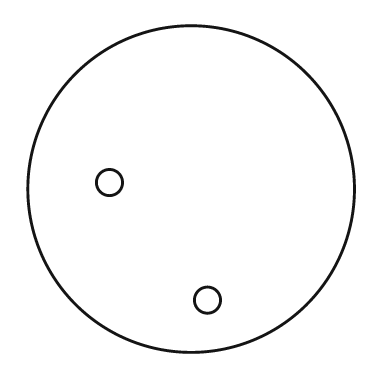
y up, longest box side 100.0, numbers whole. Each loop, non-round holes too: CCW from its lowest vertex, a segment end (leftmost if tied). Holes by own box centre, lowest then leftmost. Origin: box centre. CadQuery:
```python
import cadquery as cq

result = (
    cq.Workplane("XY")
    .moveTo(0.0, 0.0)
    .circle(50.0)
    .moveTo(5.0, -34.0)
    .circle(4.0)
    .moveTo(-25.0, 2.0)
    .circle(4.0)
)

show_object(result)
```